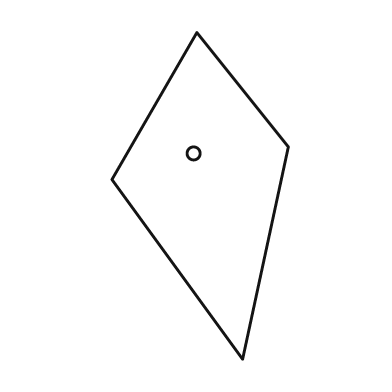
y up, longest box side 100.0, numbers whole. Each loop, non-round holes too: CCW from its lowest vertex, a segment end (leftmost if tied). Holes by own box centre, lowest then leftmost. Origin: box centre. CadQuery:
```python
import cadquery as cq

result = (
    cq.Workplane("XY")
    .moveTo(13.0, -50.0)
    .lineTo(27.0, 15.0)
    .lineTo(-1.0, 50.0)
    .lineTo(-27.0, 5.0)
    .close()
    .moveTo(-2.0, 13.0)
    .circle(2.0)
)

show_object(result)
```